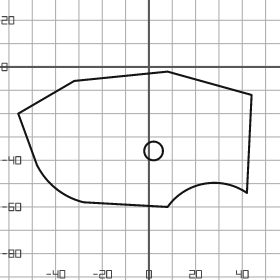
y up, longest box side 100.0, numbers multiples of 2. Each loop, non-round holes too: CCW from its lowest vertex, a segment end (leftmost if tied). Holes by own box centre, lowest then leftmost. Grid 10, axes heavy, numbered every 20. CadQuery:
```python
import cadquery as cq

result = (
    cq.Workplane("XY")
    .moveTo(8.0, -60.0)
    .threePointArc((24.0, -50.0), (42.0, -54.0))
    .lineTo(44.0, -12.0)
    .lineTo(8.0, -2.0)
    .lineTo(-32.0, -6.0)
    .lineTo(-56.0, -20.0)
    .lineTo(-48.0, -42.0)
    .threePointArc((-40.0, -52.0), (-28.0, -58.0))
    .close()
    .moveTo(2.0, -36.0)
    .circle(4.0)
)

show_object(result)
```